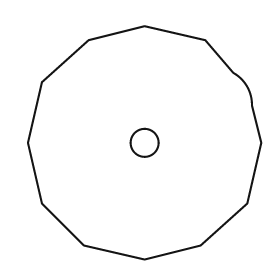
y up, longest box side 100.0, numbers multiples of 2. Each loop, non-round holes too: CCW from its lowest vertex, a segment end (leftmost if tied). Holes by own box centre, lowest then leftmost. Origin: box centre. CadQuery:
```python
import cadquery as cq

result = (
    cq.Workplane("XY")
    .moveTo(0.0, -50.0)
    .lineTo(24.0, -44.0)
    .lineTo(44.0, -26.0)
    .lineTo(50.0, 0.0)
    .lineTo(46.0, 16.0)
    .threePointArc((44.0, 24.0), (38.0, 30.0))
    .lineTo(26.0, 44.0)
    .lineTo(0.0, 50.0)
    .lineTo(-24.0, 44.0)
    .lineTo(-44.0, 26.0)
    .lineTo(-50.0, 0.0)
    .lineTo(-44.0, -26.0)
    .lineTo(-26.0, -44.0)
    .close()
    .moveTo(0.0, 0.0)
    .circle(6.0)
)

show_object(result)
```